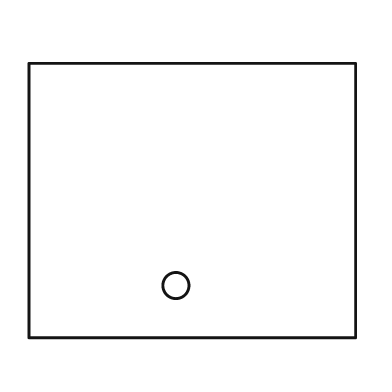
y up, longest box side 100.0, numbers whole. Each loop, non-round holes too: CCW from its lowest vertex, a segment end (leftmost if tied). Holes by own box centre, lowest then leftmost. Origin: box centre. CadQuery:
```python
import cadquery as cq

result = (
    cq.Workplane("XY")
    .moveTo(-50.0, -42.0)
    .lineTo(50.0, -42.0)
    .lineTo(50.0, 42.0)
    .lineTo(-50.0, 42.0)
    .close()
    .moveTo(-5.0, -26.0)
    .circle(4.0)
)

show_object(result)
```